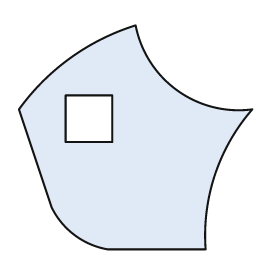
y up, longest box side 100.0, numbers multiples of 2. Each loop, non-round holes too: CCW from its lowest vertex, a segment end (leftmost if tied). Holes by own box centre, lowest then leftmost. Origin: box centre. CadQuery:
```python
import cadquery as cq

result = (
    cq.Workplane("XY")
    .moveTo(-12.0, -48.0)
    .lineTo(30.0, -48.0)
    .threePointArc((34.0, -16.0), (50.0, 12.0))
    .threePointArc((18.0, 20.0), (0.0, 48.0))
    .threePointArc((-28.0, 34.0), (-50.0, 12.0))
    .lineTo(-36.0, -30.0)
    .threePointArc((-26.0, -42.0), (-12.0, -48.0))
    .close()
    .moveTo(-30.0, -2.0)
    .lineTo(-10.0, -2.0)
    .lineTo(-10.0, 18.0)
    .lineTo(-30.0, 18.0)
    .close()
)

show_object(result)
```